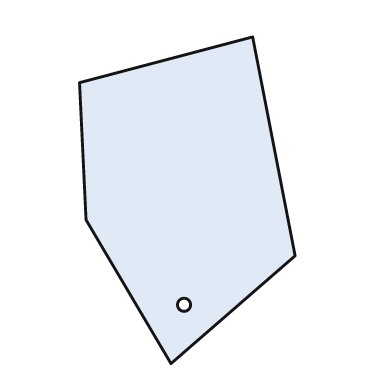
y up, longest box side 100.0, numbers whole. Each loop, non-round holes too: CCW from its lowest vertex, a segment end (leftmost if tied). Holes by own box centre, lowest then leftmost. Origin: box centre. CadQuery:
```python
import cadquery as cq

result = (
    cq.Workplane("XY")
    .moveTo(-5.0, -50.0)
    .lineTo(33.0, -17.0)
    .lineTo(20.0, 50.0)
    .lineTo(-33.0, 36.0)
    .lineTo(-31.0, -6.0)
    .close()
    .moveTo(-1.0, -32.0)
    .circle(2.0)
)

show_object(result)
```